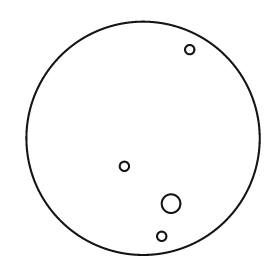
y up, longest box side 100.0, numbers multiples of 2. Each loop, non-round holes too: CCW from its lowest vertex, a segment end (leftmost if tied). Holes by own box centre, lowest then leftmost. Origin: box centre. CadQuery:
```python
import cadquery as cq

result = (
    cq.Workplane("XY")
    .moveTo(0.0, 0.0)
    .circle(50.0)
    .moveTo(8.0, -42.0)
    .circle(2.0)
    .moveTo(12.0, -28.0)
    .circle(4.0)
    .moveTo(-8.0, -12.0)
    .circle(2.0)
    .moveTo(20.0, 38.0)
    .circle(2.0)
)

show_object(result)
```